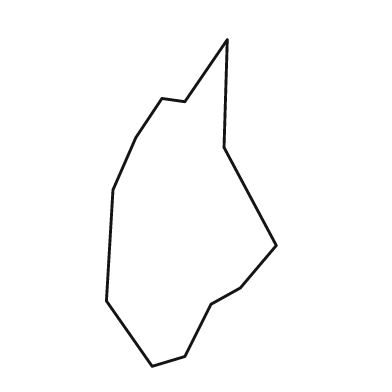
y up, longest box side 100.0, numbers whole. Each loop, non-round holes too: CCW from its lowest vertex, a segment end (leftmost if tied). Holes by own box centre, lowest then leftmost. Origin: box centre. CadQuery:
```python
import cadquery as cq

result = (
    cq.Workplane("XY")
    .moveTo(-12.0, -50.0)
    .lineTo(-2.0, -47.0)
    .lineTo(6.0, -31.0)
    .lineTo(15.0, -26.0)
    .lineTo(26.0, -13.0)
    .lineTo(10.0, 17.0)
    .lineTo(11.0, 50.0)
    .lineTo(-2.0, 31.0)
    .lineTo(-9.0, 32.0)
    .lineTo(-17.0, 20.0)
    .lineTo(-24.0, 4.0)
    .lineTo(-26.0, -30.0)
    .close()
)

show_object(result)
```